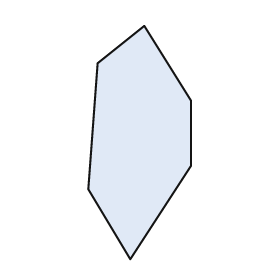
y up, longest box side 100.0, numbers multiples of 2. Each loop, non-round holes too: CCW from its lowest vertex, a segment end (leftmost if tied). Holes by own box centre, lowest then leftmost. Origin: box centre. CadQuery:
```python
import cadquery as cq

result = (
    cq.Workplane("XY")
    .moveTo(-4.0, -50.0)
    .lineTo(22.0, -10.0)
    .lineTo(22.0, 18.0)
    .lineTo(2.0, 50.0)
    .lineTo(-18.0, 34.0)
    .lineTo(-22.0, -20.0)
    .close()
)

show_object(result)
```